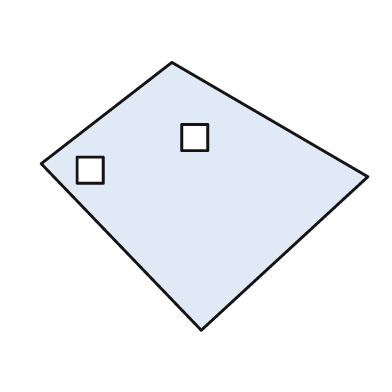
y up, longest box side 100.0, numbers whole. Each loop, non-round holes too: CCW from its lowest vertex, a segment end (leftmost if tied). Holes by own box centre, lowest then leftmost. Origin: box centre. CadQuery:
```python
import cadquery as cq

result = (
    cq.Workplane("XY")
    .moveTo(-1.0, -41.0)
    .lineTo(50.0, 6.0)
    .lineTo(-10.0, 41.0)
    .lineTo(-50.0, 10.0)
    .close()
    .moveTo(-39.0, 4.0)
    .lineTo(-31.0, 4.0)
    .lineTo(-31.0, 12.0)
    .lineTo(-39.0, 12.0)
    .close()
    .moveTo(-7.0, 14.0)
    .lineTo(1.0, 14.0)
    .lineTo(1.0, 22.0)
    .lineTo(-7.0, 22.0)
    .close()
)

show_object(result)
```